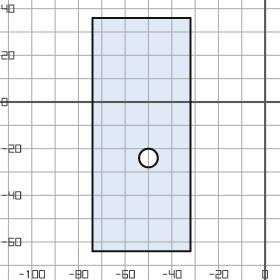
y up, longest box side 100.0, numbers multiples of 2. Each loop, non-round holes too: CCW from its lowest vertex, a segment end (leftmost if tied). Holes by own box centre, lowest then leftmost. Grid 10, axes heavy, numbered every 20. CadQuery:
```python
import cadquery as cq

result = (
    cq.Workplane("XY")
    .moveTo(-74.0, -64.0)
    .lineTo(-32.0, -64.0)
    .lineTo(-32.0, 36.0)
    .lineTo(-74.0, 36.0)
    .close()
    .moveTo(-50.0, -24.0)
    .circle(4.0)
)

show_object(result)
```